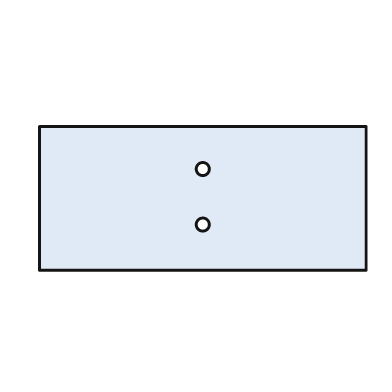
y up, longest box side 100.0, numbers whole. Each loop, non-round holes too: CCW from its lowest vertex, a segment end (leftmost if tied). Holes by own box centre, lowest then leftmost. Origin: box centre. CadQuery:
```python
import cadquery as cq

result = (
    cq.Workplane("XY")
    .moveTo(-50.0, -22.0)
    .lineTo(50.0, -22.0)
    .lineTo(50.0, 22.0)
    .lineTo(-50.0, 22.0)
    .close()
    .moveTo(0.0, -8.0)
    .circle(2.0)
    .moveTo(0.0, 9.0)
    .circle(2.0)
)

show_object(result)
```